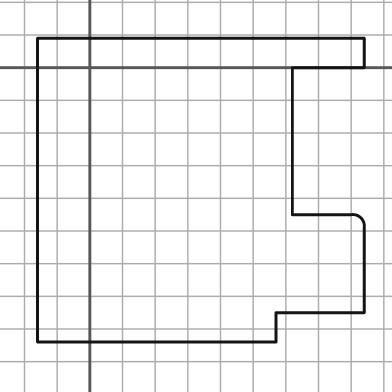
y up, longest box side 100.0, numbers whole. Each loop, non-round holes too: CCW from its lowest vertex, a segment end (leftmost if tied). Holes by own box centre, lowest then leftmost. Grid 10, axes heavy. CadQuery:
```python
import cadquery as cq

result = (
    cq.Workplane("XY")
    .moveTo(-16.0, -84.0)
    .lineTo(57.0, -84.0)
    .lineTo(57.0, -75.0)
    .lineTo(84.0, -75.0)
    .lineTo(84.0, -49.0)
    .threePointArc((83.0, -46.0), (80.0, -45.0))
    .lineTo(62.0, -45.0)
    .lineTo(62.0, 0.0)
    .lineTo(84.0, 0.0)
    .lineTo(84.0, 9.0)
    .lineTo(-16.0, 9.0)
    .close()
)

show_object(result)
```